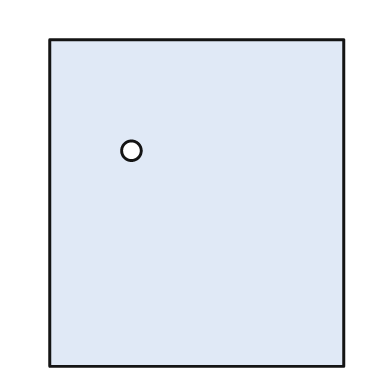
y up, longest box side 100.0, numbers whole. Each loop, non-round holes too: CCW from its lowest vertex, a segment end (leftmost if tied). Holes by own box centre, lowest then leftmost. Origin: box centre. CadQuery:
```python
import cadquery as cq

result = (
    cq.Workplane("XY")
    .moveTo(-45.0, -50.0)
    .lineTo(45.0, -50.0)
    .lineTo(45.0, 50.0)
    .lineTo(-45.0, 50.0)
    .close()
    .moveTo(-20.0, 16.0)
    .circle(3.0)
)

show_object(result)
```